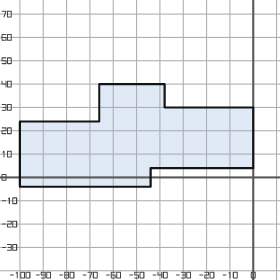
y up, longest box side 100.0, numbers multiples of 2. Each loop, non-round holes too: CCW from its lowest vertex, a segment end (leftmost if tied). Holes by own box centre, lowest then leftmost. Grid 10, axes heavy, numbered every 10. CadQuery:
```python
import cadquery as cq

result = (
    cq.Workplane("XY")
    .moveTo(-100.0, -4.0)
    .lineTo(-44.0, -4.0)
    .lineTo(-44.0, 4.0)
    .lineTo(0.0, 4.0)
    .lineTo(0.0, 30.0)
    .lineTo(-38.0, 30.0)
    .lineTo(-38.0, 40.0)
    .lineTo(-66.0, 40.0)
    .lineTo(-66.0, 24.0)
    .lineTo(-100.0, 24.0)
    .close()
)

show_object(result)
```